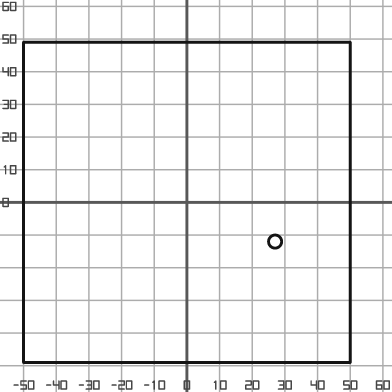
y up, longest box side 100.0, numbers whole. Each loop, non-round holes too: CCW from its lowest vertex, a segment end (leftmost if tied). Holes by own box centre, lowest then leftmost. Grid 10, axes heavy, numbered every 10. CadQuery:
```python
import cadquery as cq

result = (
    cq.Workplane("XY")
    .moveTo(-50.0, -49.0)
    .lineTo(50.0, -49.0)
    .lineTo(50.0, 49.0)
    .lineTo(-50.0, 49.0)
    .close()
    .moveTo(27.0, -12.0)
    .circle(2.0)
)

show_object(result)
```